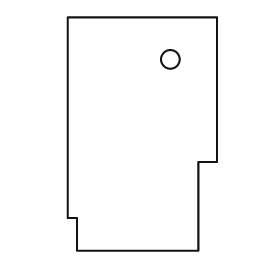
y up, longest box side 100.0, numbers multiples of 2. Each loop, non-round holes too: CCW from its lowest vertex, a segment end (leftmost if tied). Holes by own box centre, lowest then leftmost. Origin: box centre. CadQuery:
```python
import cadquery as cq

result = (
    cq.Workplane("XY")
    .moveTo(-28.0, -50.0)
    .lineTo(24.0, -50.0)
    .lineTo(24.0, -12.0)
    .lineTo(32.0, -12.0)
    .lineTo(32.0, 50.0)
    .lineTo(-32.0, 50.0)
    .lineTo(-32.0, -36.0)
    .lineTo(-28.0, -36.0)
    .close()
    .moveTo(12.0, 32.0)
    .circle(4.0)
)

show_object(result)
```